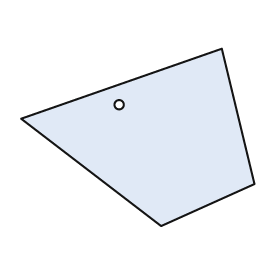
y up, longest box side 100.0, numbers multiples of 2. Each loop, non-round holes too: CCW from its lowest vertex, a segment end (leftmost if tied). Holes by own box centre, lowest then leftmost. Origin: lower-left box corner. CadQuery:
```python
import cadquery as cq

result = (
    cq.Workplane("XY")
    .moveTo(60.0, 0.0)
    .lineTo(100.0, 18.0)
    .lineTo(86.0, 76.0)
    .lineTo(0.0, 46.0)
    .close()
    .moveTo(42.0, 52.0)
    .circle(2.0)
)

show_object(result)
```